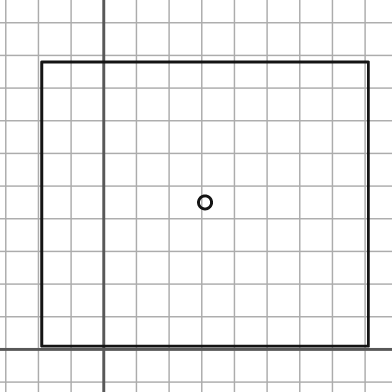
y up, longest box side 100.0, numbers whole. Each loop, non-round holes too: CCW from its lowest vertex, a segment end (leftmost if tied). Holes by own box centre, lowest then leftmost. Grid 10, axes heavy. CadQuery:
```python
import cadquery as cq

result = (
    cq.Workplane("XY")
    .moveTo(-19.0, 1.0)
    .lineTo(81.0, 1.0)
    .lineTo(81.0, 88.0)
    .lineTo(-19.0, 88.0)
    .close()
    .moveTo(31.0, 45.0)
    .circle(2.0)
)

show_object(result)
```